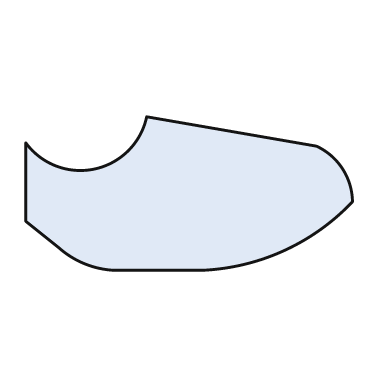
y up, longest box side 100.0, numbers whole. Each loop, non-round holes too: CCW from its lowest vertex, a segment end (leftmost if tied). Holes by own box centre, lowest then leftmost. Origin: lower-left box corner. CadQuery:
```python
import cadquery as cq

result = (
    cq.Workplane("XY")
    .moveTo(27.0, 0.0)
    .lineTo(54.0, 0.0)
    .threePointArc((79.0, 6.0), (100.0, 21.0))
    .threePointArc((97.0, 31.0), (89.0, 38.0))
    .lineTo(37.0, 47.0)
    .threePointArc((21.0, 31.0), (0.0, 39.0))
    .lineTo(0.0, 15.0)
    .lineTo(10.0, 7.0)
    .threePointArc((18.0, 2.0), (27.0, 0.0))
    .close()
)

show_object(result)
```